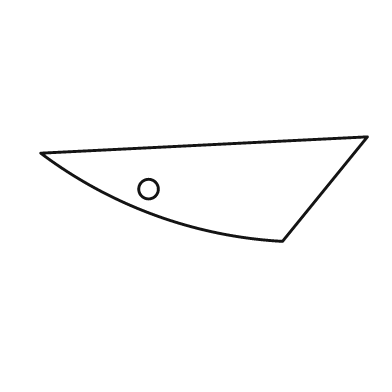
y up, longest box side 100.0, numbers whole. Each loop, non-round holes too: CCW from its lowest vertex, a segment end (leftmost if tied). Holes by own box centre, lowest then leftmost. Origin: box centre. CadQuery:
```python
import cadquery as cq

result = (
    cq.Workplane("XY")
    .moveTo(24.0, -16.0)
    .lineTo(50.0, 16.0)
    .lineTo(-50.0, 11.0)
    .threePointArc((-15.0, -8.0), (24.0, -16.0))
    .close()
    .moveTo(-17.0, 0.0)
    .circle(3.0)
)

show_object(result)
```